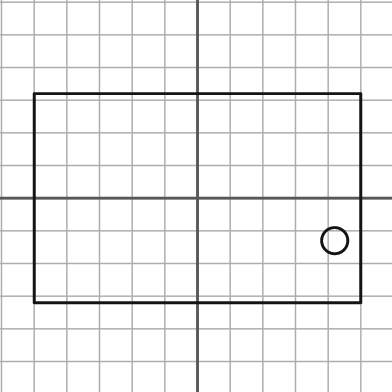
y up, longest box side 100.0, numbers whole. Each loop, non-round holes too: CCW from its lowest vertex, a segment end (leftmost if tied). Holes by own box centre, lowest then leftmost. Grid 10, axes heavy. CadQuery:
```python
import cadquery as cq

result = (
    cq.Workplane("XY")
    .moveTo(-50.0, -32.0)
    .lineTo(50.0, -32.0)
    .lineTo(50.0, 32.0)
    .lineTo(-50.0, 32.0)
    .close()
    .moveTo(42.0, -13.0)
    .circle(4.0)
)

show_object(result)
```